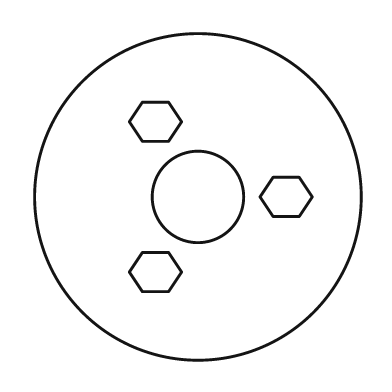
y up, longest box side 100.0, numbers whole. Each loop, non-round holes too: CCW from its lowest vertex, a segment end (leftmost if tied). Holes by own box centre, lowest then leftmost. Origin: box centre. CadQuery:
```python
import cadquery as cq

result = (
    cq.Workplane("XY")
    .moveTo(0.0, 0.0)
    .circle(50.0)
    .moveTo(-17.0, -29.0)
    .lineTo(-9.0, -29.0)
    .lineTo(-5.0, -23.0)
    .lineTo(-9.0, -17.0)
    .lineTo(-17.0, -17.0)
    .lineTo(-21.0, -23.0)
    .close()
    .moveTo(0.0, 0.0)
    .circle(14.0)
    .moveTo(23.0, -6.0)
    .lineTo(31.0, -6.0)
    .lineTo(35.0, 0.0)
    .lineTo(31.0, 6.0)
    .lineTo(23.0, 6.0)
    .lineTo(19.0, 0.0)
    .close()
    .moveTo(-17.0, 17.0)
    .lineTo(-9.0, 17.0)
    .lineTo(-5.0, 23.0)
    .lineTo(-9.0, 29.0)
    .lineTo(-17.0, 29.0)
    .lineTo(-21.0, 23.0)
    .close()
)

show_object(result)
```